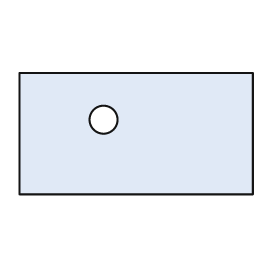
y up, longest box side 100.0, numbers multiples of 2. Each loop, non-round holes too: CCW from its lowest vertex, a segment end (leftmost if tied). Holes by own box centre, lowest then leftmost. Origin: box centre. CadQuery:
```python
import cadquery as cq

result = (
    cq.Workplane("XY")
    .moveTo(-50.0, -26.0)
    .lineTo(50.0, -26.0)
    .lineTo(50.0, 26.0)
    .lineTo(-50.0, 26.0)
    .close()
    .moveTo(-14.0, 6.0)
    .circle(6.0)
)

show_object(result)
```